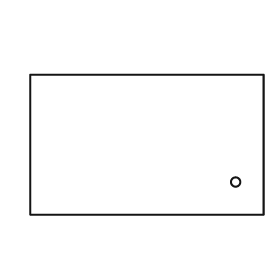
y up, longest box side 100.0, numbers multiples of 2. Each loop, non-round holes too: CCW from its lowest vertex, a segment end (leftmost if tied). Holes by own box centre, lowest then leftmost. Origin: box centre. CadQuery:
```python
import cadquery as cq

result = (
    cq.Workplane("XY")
    .moveTo(-50.0, -30.0)
    .lineTo(50.0, -30.0)
    .lineTo(50.0, 30.0)
    .lineTo(-50.0, 30.0)
    .close()
    .moveTo(38.0, -16.0)
    .circle(2.0)
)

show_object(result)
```